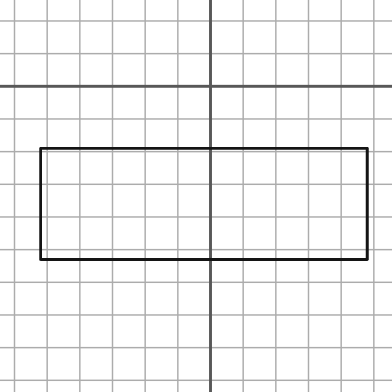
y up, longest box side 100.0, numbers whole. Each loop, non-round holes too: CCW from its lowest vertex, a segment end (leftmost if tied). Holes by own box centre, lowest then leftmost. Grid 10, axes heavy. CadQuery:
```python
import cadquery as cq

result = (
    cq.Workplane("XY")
    .moveTo(-52.0, -53.0)
    .lineTo(48.0, -53.0)
    .lineTo(48.0, -19.0)
    .lineTo(-52.0, -19.0)
    .close()
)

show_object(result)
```